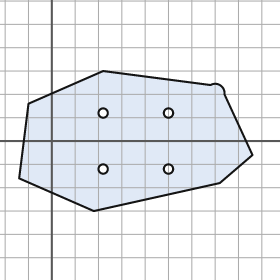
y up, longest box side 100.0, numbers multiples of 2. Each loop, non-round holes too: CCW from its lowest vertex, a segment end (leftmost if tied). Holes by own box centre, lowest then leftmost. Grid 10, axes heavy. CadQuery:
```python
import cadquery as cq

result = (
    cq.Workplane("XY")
    .moveTo(18.0, -30.0)
    .lineTo(72.0, -18.0)
    .lineTo(86.0, -6.0)
    .lineTo(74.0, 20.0)
    .threePointArc((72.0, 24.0), (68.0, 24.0))
    .lineTo(22.0, 30.0)
    .lineTo(-10.0, 16.0)
    .lineTo(-14.0, -16.0)
    .close()
    .moveTo(22.0, -12.0)
    .circle(2.0)
    .moveTo(50.0, -12.0)
    .circle(2.0)
    .moveTo(22.0, 12.0)
    .circle(2.0)
    .moveTo(50.0, 12.0)
    .circle(2.0)
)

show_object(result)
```